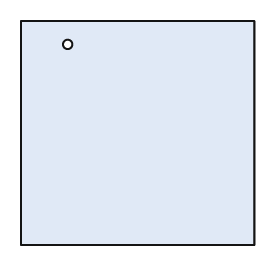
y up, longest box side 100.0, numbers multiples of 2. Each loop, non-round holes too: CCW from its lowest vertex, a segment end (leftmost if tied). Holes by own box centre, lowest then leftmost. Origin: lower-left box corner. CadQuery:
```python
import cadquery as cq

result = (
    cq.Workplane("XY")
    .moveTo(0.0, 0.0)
    .lineTo(100.0, 0.0)
    .lineTo(100.0, 96.0)
    .lineTo(0.0, 96.0)
    .close()
    .moveTo(20.0, 86.0)
    .circle(2.0)
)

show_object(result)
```